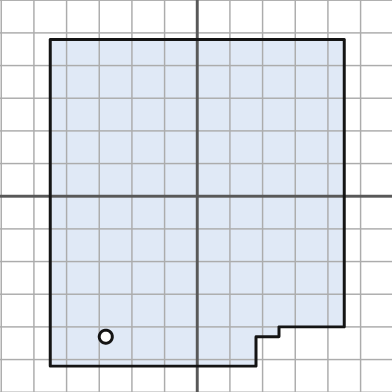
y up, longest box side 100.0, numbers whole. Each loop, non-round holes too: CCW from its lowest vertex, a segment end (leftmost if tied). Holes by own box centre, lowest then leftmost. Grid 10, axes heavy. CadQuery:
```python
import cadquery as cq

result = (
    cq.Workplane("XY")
    .moveTo(-45.0, -52.0)
    .lineTo(18.0, -52.0)
    .lineTo(18.0, -43.0)
    .lineTo(25.0, -43.0)
    .lineTo(25.0, -40.0)
    .lineTo(45.0, -40.0)
    .lineTo(45.0, 48.0)
    .lineTo(-45.0, 48.0)
    .close()
    .moveTo(-28.0, -43.0)
    .circle(2.0)
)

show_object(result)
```